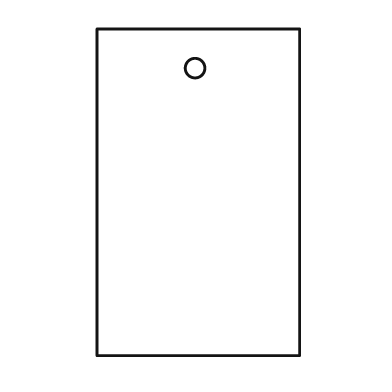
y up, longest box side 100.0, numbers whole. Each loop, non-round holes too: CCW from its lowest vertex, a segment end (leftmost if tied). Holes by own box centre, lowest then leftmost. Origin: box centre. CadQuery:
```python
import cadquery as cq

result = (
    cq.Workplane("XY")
    .moveTo(-31.0, -50.0)
    .lineTo(31.0, -50.0)
    .lineTo(31.0, 50.0)
    .lineTo(-31.0, 50.0)
    .close()
    .moveTo(-1.0, 38.0)
    .circle(3.0)
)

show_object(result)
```